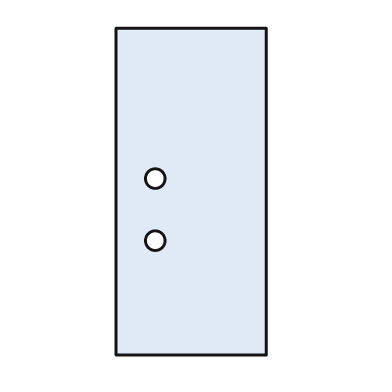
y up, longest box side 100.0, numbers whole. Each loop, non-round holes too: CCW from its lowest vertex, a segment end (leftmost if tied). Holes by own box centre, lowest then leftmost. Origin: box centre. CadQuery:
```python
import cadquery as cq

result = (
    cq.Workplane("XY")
    .moveTo(-23.0, -50.0)
    .lineTo(23.0, -50.0)
    .lineTo(23.0, 50.0)
    .lineTo(-23.0, 50.0)
    .close()
    .moveTo(-11.0, -15.0)
    .circle(3.0)
    .moveTo(-11.0, 4.0)
    .circle(3.0)
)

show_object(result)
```